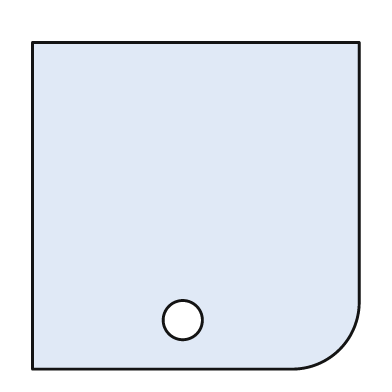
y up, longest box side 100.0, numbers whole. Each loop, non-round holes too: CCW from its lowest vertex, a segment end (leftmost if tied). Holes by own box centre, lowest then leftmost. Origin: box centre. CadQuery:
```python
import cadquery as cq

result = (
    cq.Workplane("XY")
    .moveTo(-50.0, -50.0)
    .lineTo(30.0, -50.0)
    .threePointArc((44.0, -44.0), (50.0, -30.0))
    .lineTo(50.0, 50.0)
    .lineTo(-50.0, 50.0)
    .close()
    .moveTo(-4.0, -35.0)
    .circle(6.0)
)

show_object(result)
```